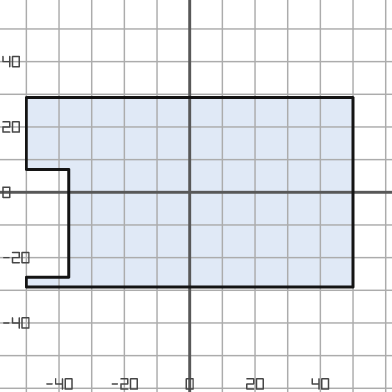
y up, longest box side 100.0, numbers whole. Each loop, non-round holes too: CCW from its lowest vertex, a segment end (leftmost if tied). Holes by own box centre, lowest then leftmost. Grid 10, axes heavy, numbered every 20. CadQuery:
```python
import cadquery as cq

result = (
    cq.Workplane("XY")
    .moveTo(-50.0, -29.0)
    .lineTo(50.0, -29.0)
    .lineTo(50.0, 29.0)
    .lineTo(-50.0, 29.0)
    .lineTo(-50.0, 7.0)
    .lineTo(-37.0, 7.0)
    .lineTo(-37.0, -26.0)
    .lineTo(-50.0, -26.0)
    .close()
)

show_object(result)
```